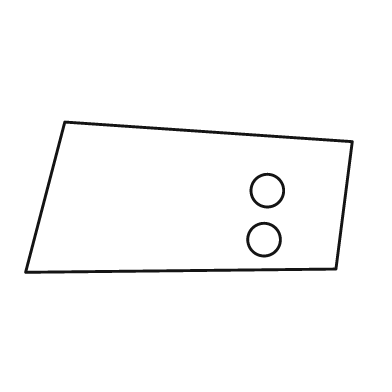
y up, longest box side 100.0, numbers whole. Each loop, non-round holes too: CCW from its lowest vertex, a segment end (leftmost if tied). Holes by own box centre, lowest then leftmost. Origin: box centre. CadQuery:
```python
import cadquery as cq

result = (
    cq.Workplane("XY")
    .moveTo(-50.0, -23.0)
    .lineTo(45.0, -22.0)
    .lineTo(50.0, 17.0)
    .lineTo(-38.0, 23.0)
    .close()
    .moveTo(23.0, -13.0)
    .circle(5.0)
    .moveTo(24.0, 2.0)
    .circle(5.0)
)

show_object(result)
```